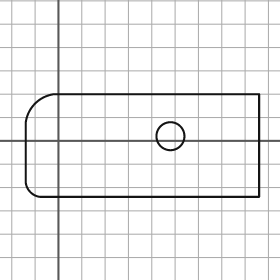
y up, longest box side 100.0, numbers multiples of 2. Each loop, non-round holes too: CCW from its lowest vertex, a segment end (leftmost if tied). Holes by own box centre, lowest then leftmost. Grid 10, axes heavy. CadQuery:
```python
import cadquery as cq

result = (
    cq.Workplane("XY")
    .moveTo(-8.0, -24.0)
    .lineTo(86.0, -24.0)
    .lineTo(86.0, 20.0)
    .lineTo(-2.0, 20.0)
    .threePointArc((-10.0, 16.0), (-14.0, 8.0))
    .lineTo(-14.0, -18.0)
    .threePointArc((-12.0, -22.0), (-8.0, -24.0))
    .close()
    .moveTo(48.0, 2.0)
    .circle(6.0)
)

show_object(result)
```